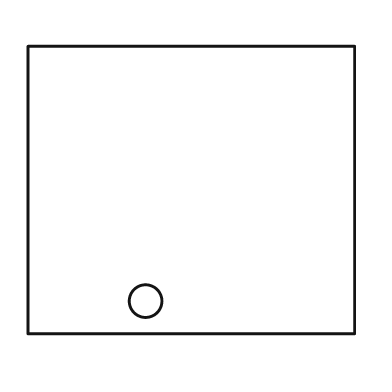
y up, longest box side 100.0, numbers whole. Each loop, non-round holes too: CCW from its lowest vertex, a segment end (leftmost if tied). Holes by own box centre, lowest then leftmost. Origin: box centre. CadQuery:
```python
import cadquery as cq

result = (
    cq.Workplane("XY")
    .moveTo(-50.0, -44.0)
    .lineTo(50.0, -44.0)
    .lineTo(50.0, 44.0)
    .lineTo(-50.0, 44.0)
    .close()
    .moveTo(-14.0, -34.0)
    .circle(5.0)
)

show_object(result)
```